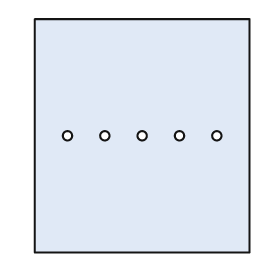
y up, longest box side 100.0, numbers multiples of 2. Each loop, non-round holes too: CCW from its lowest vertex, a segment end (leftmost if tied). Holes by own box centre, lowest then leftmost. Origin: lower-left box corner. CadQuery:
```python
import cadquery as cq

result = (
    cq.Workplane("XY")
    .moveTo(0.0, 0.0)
    .lineTo(92.0, 0.0)
    .lineTo(92.0, 100.0)
    .lineTo(0.0, 100.0)
    .close()
    .moveTo(14.0, 50.0)
    .circle(2.0)
    .moveTo(30.0, 50.0)
    .circle(2.0)
    .moveTo(46.0, 50.0)
    .circle(2.0)
    .moveTo(62.0, 50.0)
    .circle(2.0)
    .moveTo(78.0, 50.0)
    .circle(2.0)
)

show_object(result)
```